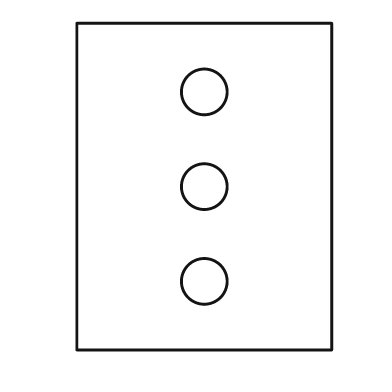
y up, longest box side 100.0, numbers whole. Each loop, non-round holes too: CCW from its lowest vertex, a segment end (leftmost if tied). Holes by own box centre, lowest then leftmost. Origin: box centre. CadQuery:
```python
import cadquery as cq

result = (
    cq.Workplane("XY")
    .moveTo(-39.0, -50.0)
    .lineTo(39.0, -50.0)
    .lineTo(39.0, 50.0)
    .lineTo(-39.0, 50.0)
    .close()
    .moveTo(0.0, -29.0)
    .circle(7.0)
    .moveTo(0.0, 0.0)
    .circle(7.0)
    .moveTo(0.0, 29.0)
    .circle(7.0)
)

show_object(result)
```